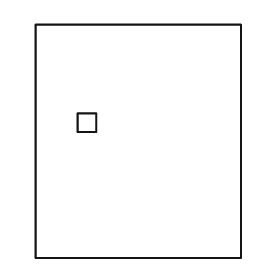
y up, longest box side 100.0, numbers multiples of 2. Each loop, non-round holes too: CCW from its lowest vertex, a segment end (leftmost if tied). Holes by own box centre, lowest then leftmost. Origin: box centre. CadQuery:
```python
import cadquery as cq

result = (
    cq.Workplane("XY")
    .moveTo(-44.0, -50.0)
    .lineTo(44.0, -50.0)
    .lineTo(44.0, 50.0)
    .lineTo(-44.0, 50.0)
    .close()
    .moveTo(-26.0, 4.0)
    .lineTo(-18.0, 4.0)
    .lineTo(-18.0, 12.0)
    .lineTo(-26.0, 12.0)
    .close()
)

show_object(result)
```